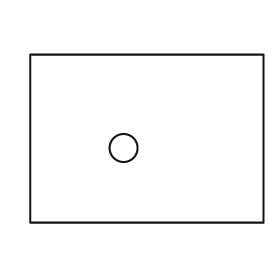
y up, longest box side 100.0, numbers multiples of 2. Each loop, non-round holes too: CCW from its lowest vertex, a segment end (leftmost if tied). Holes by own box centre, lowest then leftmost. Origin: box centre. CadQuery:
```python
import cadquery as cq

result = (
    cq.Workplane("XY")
    .moveTo(-50.0, -36.0)
    .lineTo(50.0, -36.0)
    .lineTo(50.0, 36.0)
    .lineTo(-50.0, 36.0)
    .close()
    .moveTo(-10.0, -4.0)
    .circle(6.0)
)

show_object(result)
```